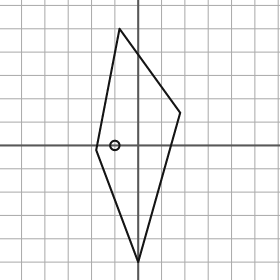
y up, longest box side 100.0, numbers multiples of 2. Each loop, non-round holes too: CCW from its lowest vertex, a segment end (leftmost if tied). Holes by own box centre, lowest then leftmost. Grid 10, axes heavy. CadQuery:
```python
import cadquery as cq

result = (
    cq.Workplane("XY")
    .moveTo(0.0, -50.0)
    .lineTo(18.0, 14.0)
    .lineTo(-8.0, 50.0)
    .lineTo(-18.0, -2.0)
    .close()
    .moveTo(-10.0, 0.0)
    .circle(2.0)
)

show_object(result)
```